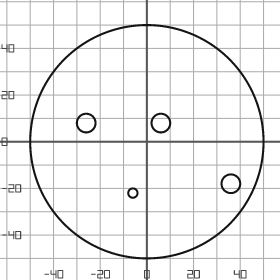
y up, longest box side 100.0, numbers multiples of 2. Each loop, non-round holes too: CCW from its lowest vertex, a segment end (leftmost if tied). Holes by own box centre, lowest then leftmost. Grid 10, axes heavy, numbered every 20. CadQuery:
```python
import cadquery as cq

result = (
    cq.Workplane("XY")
    .moveTo(0.0, 0.0)
    .circle(50.0)
    .moveTo(-6.0, -22.0)
    .circle(2.0)
    .moveTo(36.0, -18.0)
    .circle(4.0)
    .moveTo(-26.0, 8.0)
    .circle(4.0)
    .moveTo(6.0, 8.0)
    .circle(4.0)
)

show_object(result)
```